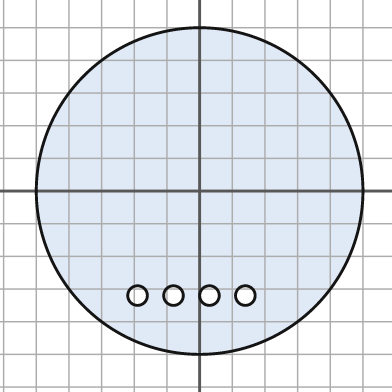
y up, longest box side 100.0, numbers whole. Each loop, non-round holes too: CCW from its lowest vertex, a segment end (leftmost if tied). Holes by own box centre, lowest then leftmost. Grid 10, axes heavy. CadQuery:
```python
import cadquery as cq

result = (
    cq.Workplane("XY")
    .moveTo(0.0, 0.0)
    .circle(50.0)
    .moveTo(-19.0, -32.0)
    .circle(3.0)
    .moveTo(-8.0, -32.0)
    .circle(3.0)
    .moveTo(3.0, -32.0)
    .circle(3.0)
    .moveTo(14.0, -32.0)
    .circle(3.0)
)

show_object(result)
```